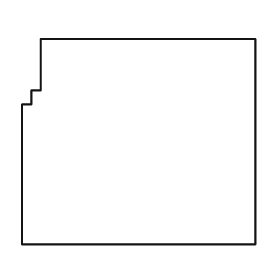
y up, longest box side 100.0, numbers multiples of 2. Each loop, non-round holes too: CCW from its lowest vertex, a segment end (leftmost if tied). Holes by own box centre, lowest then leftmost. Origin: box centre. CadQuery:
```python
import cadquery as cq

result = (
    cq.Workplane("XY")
    .moveTo(-50.0, -44.0)
    .lineTo(50.0, -44.0)
    .lineTo(50.0, 44.0)
    .lineTo(-42.0, 44.0)
    .lineTo(-42.0, 22.0)
    .lineTo(-46.0, 22.0)
    .lineTo(-46.0, 16.0)
    .lineTo(-50.0, 16.0)
    .close()
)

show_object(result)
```